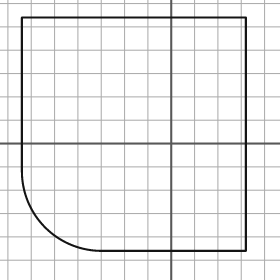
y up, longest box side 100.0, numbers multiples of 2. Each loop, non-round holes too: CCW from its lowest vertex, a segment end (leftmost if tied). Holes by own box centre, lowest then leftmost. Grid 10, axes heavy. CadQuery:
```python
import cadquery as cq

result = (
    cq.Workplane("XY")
    .moveTo(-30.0, -46.0)
    .lineTo(32.0, -46.0)
    .lineTo(32.0, 54.0)
    .lineTo(-64.0, 54.0)
    .lineTo(-64.0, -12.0)
    .threePointArc((-54.0, -36.0), (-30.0, -46.0))
    .close()
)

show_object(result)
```